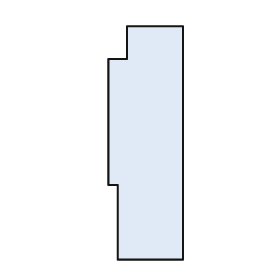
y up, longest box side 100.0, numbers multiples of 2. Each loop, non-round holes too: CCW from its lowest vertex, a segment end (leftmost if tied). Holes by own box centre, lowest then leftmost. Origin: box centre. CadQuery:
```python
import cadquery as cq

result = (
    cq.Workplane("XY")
    .moveTo(-12.0, -50.0)
    .lineTo(16.0, -50.0)
    .lineTo(16.0, 50.0)
    .lineTo(-8.0, 50.0)
    .lineTo(-8.0, 36.0)
    .lineTo(-16.0, 36.0)
    .lineTo(-16.0, -18.0)
    .lineTo(-12.0, -18.0)
    .close()
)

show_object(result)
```